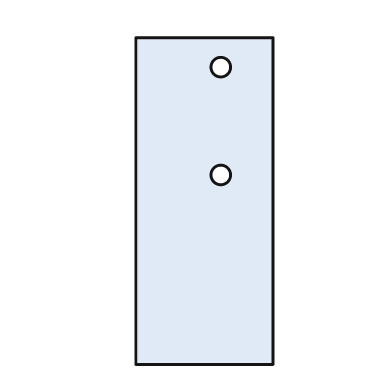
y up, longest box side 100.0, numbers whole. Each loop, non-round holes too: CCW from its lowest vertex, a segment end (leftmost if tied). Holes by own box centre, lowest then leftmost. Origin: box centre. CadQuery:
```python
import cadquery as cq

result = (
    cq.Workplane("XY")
    .moveTo(-21.0, -50.0)
    .lineTo(21.0, -50.0)
    .lineTo(21.0, 50.0)
    .lineTo(-21.0, 50.0)
    .close()
    .moveTo(5.0, 8.0)
    .circle(3.0)
    .moveTo(5.0, 41.0)
    .circle(3.0)
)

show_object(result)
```